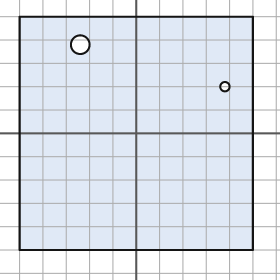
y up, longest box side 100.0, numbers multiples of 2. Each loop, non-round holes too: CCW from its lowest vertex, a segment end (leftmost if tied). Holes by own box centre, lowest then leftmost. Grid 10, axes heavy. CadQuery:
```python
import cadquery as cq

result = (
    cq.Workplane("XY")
    .moveTo(-50.0, -50.0)
    .lineTo(50.0, -50.0)
    .lineTo(50.0, 50.0)
    .lineTo(-50.0, 50.0)
    .close()
    .moveTo(38.0, 20.0)
    .circle(2.0)
    .moveTo(-24.0, 38.0)
    .circle(4.0)
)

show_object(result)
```